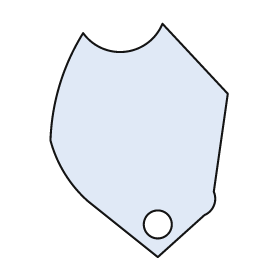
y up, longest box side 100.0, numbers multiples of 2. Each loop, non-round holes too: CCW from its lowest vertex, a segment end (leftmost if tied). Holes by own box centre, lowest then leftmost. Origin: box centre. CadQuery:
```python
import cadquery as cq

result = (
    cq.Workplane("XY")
    .moveTo(8.0, -50.0)
    .lineTo(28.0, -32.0)
    .threePointArc((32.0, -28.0), (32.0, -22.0))
    .lineTo(38.0, 20.0)
    .lineTo(10.0, 50.0)
    .threePointArc((-6.0, 38.0), (-24.0, 46.0))
    .threePointArc((-34.0, 24.0), (-38.0, 0.0))
    .threePointArc((-32.0, -14.0), (-22.0, -26.0))
    .close()
    .moveTo(8.0, -36.0)
    .circle(6.0)
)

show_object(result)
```